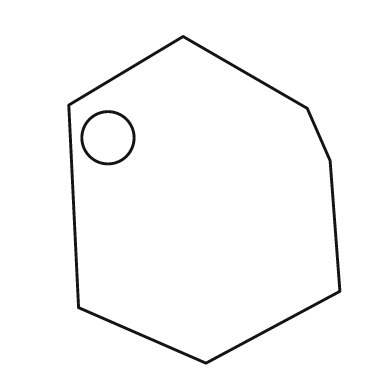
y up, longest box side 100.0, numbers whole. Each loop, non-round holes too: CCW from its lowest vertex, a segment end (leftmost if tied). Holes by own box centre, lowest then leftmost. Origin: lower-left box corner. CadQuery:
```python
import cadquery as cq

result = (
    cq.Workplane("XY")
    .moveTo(42.0, 0.0)
    .lineTo(83.0, 22.0)
    .lineTo(80.0, 62.0)
    .lineTo(73.0, 78.0)
    .lineTo(35.0, 100.0)
    .lineTo(0.0, 79.0)
    .lineTo(3.0, 17.0)
    .close()
    .moveTo(12.0, 69.0)
    .circle(8.0)
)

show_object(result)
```